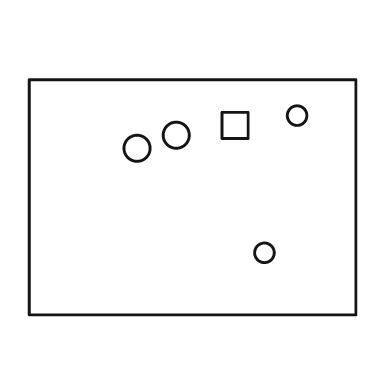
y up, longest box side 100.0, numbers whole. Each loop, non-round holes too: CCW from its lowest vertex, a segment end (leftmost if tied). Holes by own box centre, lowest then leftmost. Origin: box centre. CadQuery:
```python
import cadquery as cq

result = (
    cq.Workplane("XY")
    .moveTo(-50.0, -36.0)
    .lineTo(50.0, -36.0)
    .lineTo(50.0, 36.0)
    .lineTo(-50.0, 36.0)
    .close()
    .moveTo(22.0, -17.0)
    .circle(3.0)
    .moveTo(-17.0, 15.0)
    .circle(4.0)
    .moveTo(-5.0, 19.0)
    .circle(4.0)
    .moveTo(9.0, 18.0)
    .lineTo(17.0, 18.0)
    .lineTo(17.0, 26.0)
    .lineTo(9.0, 26.0)
    .close()
    .moveTo(32.0, 25.0)
    .circle(3.0)
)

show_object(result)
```